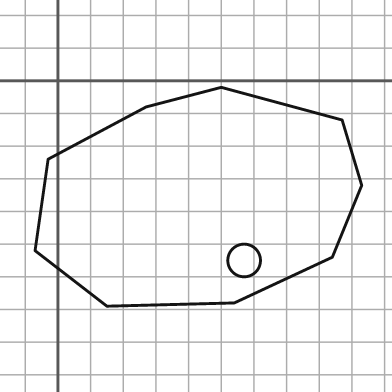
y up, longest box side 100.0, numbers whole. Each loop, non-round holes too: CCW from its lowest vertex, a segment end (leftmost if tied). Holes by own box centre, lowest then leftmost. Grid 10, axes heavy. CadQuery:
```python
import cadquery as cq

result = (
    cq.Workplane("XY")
    .moveTo(15.0, -69.0)
    .lineTo(54.0, -68.0)
    .lineTo(84.0, -54.0)
    .lineTo(93.0, -32.0)
    .lineTo(87.0, -12.0)
    .lineTo(50.0, -2.0)
    .lineTo(27.0, -8.0)
    .lineTo(-3.0, -24.0)
    .lineTo(-7.0, -52.0)
    .close()
    .moveTo(57.0, -55.0)
    .circle(5.0)
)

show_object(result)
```